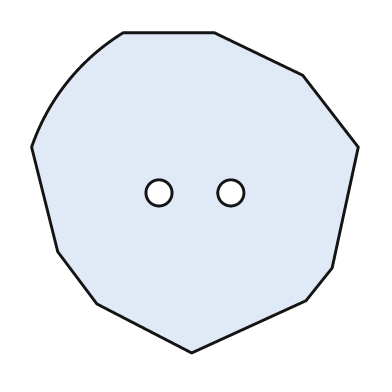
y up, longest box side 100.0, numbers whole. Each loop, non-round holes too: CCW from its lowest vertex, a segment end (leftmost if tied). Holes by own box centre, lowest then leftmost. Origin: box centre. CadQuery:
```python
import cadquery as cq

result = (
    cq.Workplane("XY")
    .moveTo(-1.0, -49.0)
    .lineTo(34.0, -33.0)
    .lineTo(42.0, -23.0)
    .lineTo(50.0, 14.0)
    .lineTo(33.0, 36.0)
    .lineTo(6.0, 49.0)
    .lineTo(-22.0, 49.0)
    .threePointArc((-39.0, 34.0), (-50.0, 14.0))
    .lineTo(-42.0, -18.0)
    .lineTo(-30.0, -34.0)
    .close()
    .moveTo(-11.0, 0.0)
    .circle(4.0)
    .moveTo(11.0, 0.0)
    .circle(4.0)
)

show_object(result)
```